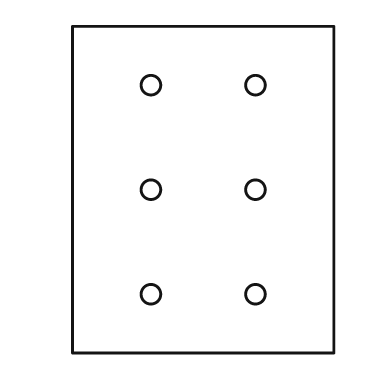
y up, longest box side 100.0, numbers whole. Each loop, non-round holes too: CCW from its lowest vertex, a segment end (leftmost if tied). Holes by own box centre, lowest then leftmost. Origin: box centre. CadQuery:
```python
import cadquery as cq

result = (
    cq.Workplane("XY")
    .moveTo(-40.0, -50.0)
    .lineTo(40.0, -50.0)
    .lineTo(40.0, 50.0)
    .lineTo(-40.0, 50.0)
    .close()
    .moveTo(-16.0, -32.0)
    .circle(3.0)
    .moveTo(16.0, -32.0)
    .circle(3.0)
    .moveTo(-16.0, 0.0)
    .circle(3.0)
    .moveTo(16.0, 0.0)
    .circle(3.0)
    .moveTo(-16.0, 32.0)
    .circle(3.0)
    .moveTo(16.0, 32.0)
    .circle(3.0)
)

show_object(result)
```